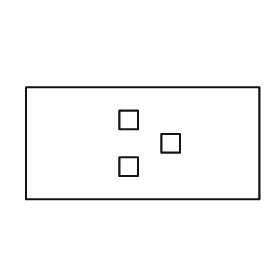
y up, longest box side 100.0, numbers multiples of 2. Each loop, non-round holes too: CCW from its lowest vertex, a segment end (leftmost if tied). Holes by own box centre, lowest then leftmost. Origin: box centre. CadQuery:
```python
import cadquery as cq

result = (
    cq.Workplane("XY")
    .moveTo(-50.0, -24.0)
    .lineTo(50.0, -24.0)
    .lineTo(50.0, 24.0)
    .lineTo(-50.0, 24.0)
    .close()
    .moveTo(-10.0, -14.0)
    .lineTo(-2.0, -14.0)
    .lineTo(-2.0, -6.0)
    .lineTo(-10.0, -6.0)
    .close()
    .moveTo(8.0, -4.0)
    .lineTo(16.0, -4.0)
    .lineTo(16.0, 4.0)
    .lineTo(8.0, 4.0)
    .close()
    .moveTo(-10.0, 6.0)
    .lineTo(-2.0, 6.0)
    .lineTo(-2.0, 14.0)
    .lineTo(-10.0, 14.0)
    .close()
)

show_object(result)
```